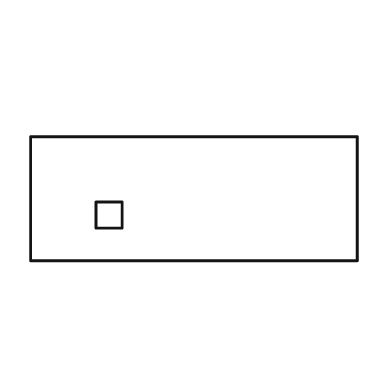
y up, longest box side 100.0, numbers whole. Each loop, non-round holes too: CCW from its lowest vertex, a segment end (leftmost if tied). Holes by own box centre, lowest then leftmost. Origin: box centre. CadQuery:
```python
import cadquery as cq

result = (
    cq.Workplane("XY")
    .moveTo(-50.0, -19.0)
    .lineTo(50.0, -19.0)
    .lineTo(50.0, 19.0)
    .lineTo(-50.0, 19.0)
    .close()
    .moveTo(-30.0, -9.0)
    .lineTo(-22.0, -9.0)
    .lineTo(-22.0, -1.0)
    .lineTo(-30.0, -1.0)
    .close()
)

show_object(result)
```